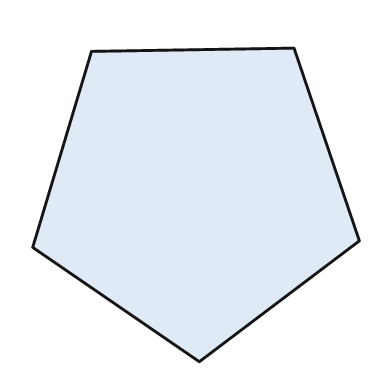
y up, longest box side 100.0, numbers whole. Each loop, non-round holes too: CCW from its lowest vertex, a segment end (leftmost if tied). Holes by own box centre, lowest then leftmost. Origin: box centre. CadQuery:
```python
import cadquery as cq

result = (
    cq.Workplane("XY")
    .moveTo(1.0, -48.0)
    .lineTo(50.0, -11.0)
    .lineTo(30.0, 48.0)
    .lineTo(-32.0, 47.0)
    .lineTo(-50.0, -13.0)
    .close()
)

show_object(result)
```